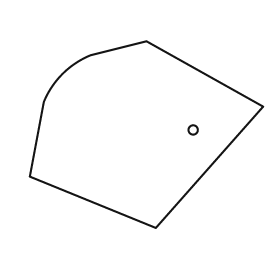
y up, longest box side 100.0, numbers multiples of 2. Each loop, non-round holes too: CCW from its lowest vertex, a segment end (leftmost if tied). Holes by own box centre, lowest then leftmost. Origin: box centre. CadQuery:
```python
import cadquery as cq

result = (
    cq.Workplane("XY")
    .moveTo(4.0, -40.0)
    .lineTo(50.0, 12.0)
    .lineTo(0.0, 40.0)
    .lineTo(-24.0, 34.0)
    .threePointArc((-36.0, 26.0), (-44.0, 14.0))
    .lineTo(-50.0, -18.0)
    .close()
    .moveTo(20.0, 2.0)
    .circle(2.0)
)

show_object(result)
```